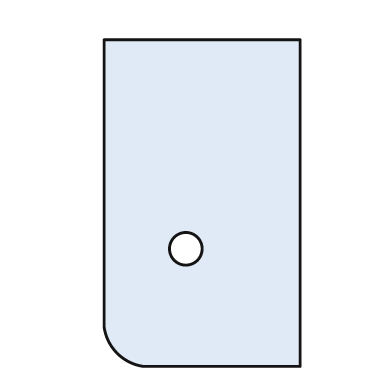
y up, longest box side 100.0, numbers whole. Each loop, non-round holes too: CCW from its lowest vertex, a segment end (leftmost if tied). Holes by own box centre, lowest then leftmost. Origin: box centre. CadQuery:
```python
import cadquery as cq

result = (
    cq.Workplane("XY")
    .moveTo(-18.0, -50.0)
    .lineTo(30.0, -50.0)
    .lineTo(30.0, 50.0)
    .lineTo(-30.0, 50.0)
    .lineTo(-30.0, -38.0)
    .threePointArc((-26.0, -46.0), (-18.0, -50.0))
    .close()
    .moveTo(-5.0, -14.0)
    .circle(5.0)
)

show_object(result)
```